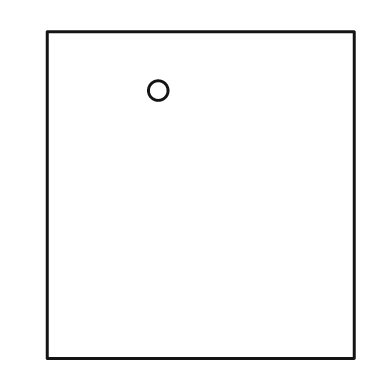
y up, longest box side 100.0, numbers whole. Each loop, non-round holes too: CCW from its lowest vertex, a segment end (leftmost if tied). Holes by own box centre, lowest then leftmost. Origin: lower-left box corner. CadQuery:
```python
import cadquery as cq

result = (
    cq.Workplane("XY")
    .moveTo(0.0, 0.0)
    .lineTo(94.0, 0.0)
    .lineTo(94.0, 100.0)
    .lineTo(0.0, 100.0)
    .close()
    .moveTo(34.0, 82.0)
    .circle(3.0)
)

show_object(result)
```